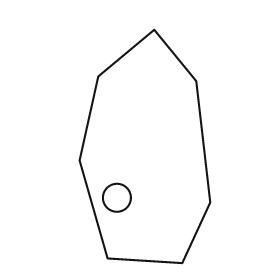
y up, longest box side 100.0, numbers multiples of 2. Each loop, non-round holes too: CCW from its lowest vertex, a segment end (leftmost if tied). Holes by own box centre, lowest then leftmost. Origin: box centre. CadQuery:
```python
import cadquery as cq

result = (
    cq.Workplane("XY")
    .moveTo(16.0, -50.0)
    .lineTo(28.0, -24.0)
    .lineTo(22.0, 28.0)
    .lineTo(4.0, 50.0)
    .lineTo(-20.0, 30.0)
    .lineTo(-28.0, -6.0)
    .lineTo(-16.0, -48.0)
    .close()
    .moveTo(-12.0, -22.0)
    .circle(6.0)
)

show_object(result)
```